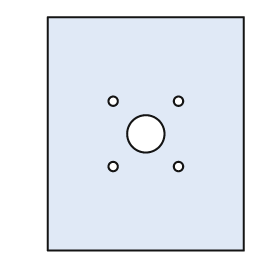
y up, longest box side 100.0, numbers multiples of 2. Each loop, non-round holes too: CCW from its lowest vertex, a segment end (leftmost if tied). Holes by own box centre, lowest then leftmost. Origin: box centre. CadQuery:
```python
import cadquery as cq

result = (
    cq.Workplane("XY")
    .moveTo(-42.0, -50.0)
    .lineTo(42.0, -50.0)
    .lineTo(42.0, 50.0)
    .lineTo(-42.0, 50.0)
    .close()
    .moveTo(-14.0, -14.0)
    .circle(2.0)
    .moveTo(14.0, -14.0)
    .circle(2.0)
    .moveTo(0.0, 0.0)
    .circle(8.0)
    .moveTo(-14.0, 14.0)
    .circle(2.0)
    .moveTo(14.0, 14.0)
    .circle(2.0)
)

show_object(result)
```